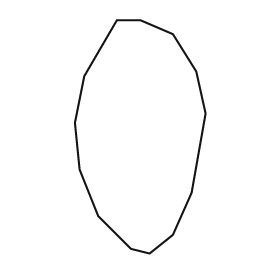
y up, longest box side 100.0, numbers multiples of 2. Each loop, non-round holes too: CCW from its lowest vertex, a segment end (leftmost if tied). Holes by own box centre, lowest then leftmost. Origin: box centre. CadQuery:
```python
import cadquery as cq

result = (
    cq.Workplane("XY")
    .moveTo(4.0, -50.0)
    .lineTo(14.0, -42.0)
    .lineTo(22.0, -24.0)
    .lineTo(28.0, 10.0)
    .lineTo(24.0, 28.0)
    .lineTo(14.0, 44.0)
    .lineTo(0.0, 50.0)
    .lineTo(-10.0, 50.0)
    .lineTo(-24.0, 26.0)
    .lineTo(-28.0, 6.0)
    .lineTo(-26.0, -14.0)
    .lineTo(-18.0, -34.0)
    .lineTo(-4.0, -48.0)
    .close()
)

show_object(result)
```